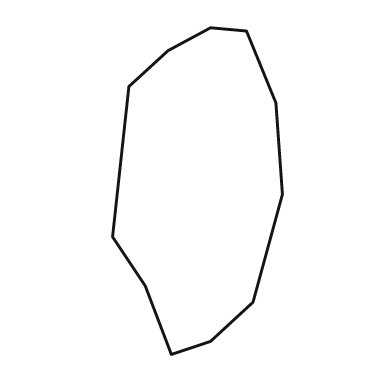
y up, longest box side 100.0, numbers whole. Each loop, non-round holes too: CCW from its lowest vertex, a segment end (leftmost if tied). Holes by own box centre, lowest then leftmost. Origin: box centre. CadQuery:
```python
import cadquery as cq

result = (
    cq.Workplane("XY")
    .moveTo(-8.0, -50.0)
    .lineTo(4.0, -46.0)
    .lineTo(17.0, -34.0)
    .lineTo(26.0, -1.0)
    .lineTo(24.0, 27.0)
    .lineTo(15.0, 49.0)
    .lineTo(4.0, 50.0)
    .lineTo(-9.0, 43.0)
    .lineTo(-21.0, 32.0)
    .lineTo(-26.0, -14.0)
    .lineTo(-16.0, -29.0)
    .close()
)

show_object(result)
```